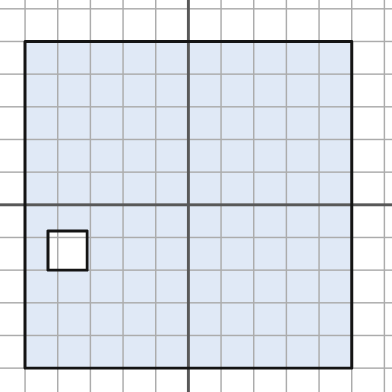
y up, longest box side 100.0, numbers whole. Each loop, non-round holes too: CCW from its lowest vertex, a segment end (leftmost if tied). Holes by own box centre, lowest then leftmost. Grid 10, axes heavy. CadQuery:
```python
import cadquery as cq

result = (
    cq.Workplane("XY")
    .moveTo(-50.0, -50.0)
    .lineTo(50.0, -50.0)
    .lineTo(50.0, 50.0)
    .lineTo(-50.0, 50.0)
    .close()
    .moveTo(-43.0, -20.0)
    .lineTo(-31.0, -20.0)
    .lineTo(-31.0, -8.0)
    .lineTo(-43.0, -8.0)
    .close()
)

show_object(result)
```